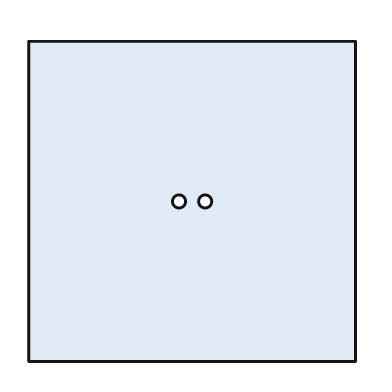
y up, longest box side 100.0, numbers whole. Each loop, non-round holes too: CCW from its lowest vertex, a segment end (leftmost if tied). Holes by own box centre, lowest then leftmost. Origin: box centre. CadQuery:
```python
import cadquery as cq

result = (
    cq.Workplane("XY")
    .moveTo(-50.0, -49.0)
    .lineTo(50.0, -49.0)
    .lineTo(50.0, 49.0)
    .lineTo(-50.0, 49.0)
    .close()
    .moveTo(-4.0, 0.0)
    .circle(2.0)
    .moveTo(4.0, 0.0)
    .circle(2.0)
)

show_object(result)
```